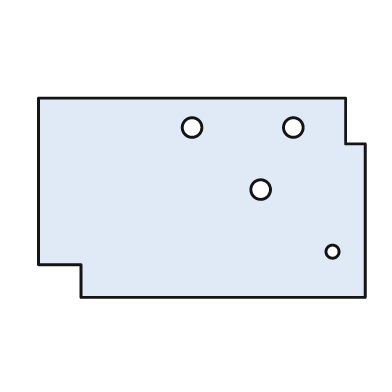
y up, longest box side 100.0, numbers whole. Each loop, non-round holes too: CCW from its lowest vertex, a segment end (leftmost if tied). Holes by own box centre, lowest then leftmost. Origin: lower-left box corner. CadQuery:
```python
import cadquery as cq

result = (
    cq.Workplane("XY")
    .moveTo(13.0, 0.0)
    .lineTo(100.0, 0.0)
    .lineTo(100.0, 47.0)
    .lineTo(94.0, 47.0)
    .lineTo(94.0, 61.0)
    .lineTo(0.0, 61.0)
    .lineTo(0.0, 10.0)
    .lineTo(13.0, 10.0)
    .close()
    .moveTo(90.0, 14.0)
    .circle(2.0)
    .moveTo(68.0, 33.0)
    .circle(3.0)
    .moveTo(47.0, 52.0)
    .circle(3.0)
    .moveTo(78.0, 52.0)
    .circle(3.0)
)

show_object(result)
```